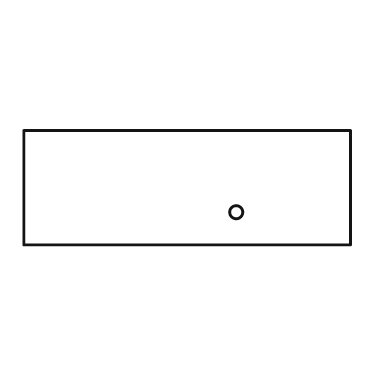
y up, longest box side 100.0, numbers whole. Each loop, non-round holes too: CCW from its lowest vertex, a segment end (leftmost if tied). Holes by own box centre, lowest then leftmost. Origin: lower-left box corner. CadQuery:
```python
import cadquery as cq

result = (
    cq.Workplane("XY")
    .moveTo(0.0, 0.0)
    .lineTo(100.0, 0.0)
    .lineTo(100.0, 35.0)
    .lineTo(0.0, 35.0)
    .close()
    .moveTo(65.0, 10.0)
    .circle(2.0)
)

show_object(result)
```